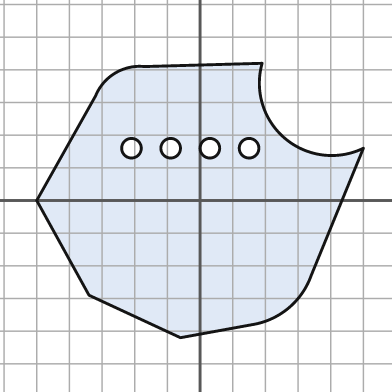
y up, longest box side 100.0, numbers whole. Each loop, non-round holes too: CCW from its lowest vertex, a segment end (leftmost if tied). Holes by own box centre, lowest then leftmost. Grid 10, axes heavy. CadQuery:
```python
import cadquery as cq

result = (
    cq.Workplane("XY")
    .moveTo(-6.0, -42.0)
    .lineTo(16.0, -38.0)
    .threePointArc((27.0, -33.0), (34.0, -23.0))
    .lineTo(50.0, 16.0)
    .threePointArc((26.0, 19.0), (19.0, 42.0))
    .lineTo(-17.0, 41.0)
    .threePointArc((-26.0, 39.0), (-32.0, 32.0))
    .lineTo(-50.0, 0.0)
    .lineTo(-34.0, -29.0)
    .close()
    .moveTo(-21.0, 16.0)
    .circle(3.0)
    .moveTo(-9.0, 16.0)
    .circle(3.0)
    .moveTo(3.0, 16.0)
    .circle(3.0)
    .moveTo(15.0, 16.0)
    .circle(3.0)
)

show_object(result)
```